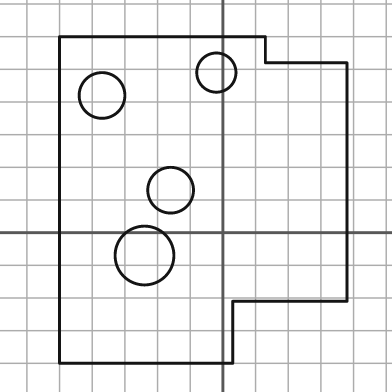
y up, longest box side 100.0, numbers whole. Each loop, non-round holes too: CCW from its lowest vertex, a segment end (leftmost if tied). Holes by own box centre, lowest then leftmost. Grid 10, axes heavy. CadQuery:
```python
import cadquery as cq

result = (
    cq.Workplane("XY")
    .moveTo(-50.0, -40.0)
    .lineTo(3.0, -40.0)
    .lineTo(3.0, -21.0)
    .lineTo(38.0, -21.0)
    .lineTo(38.0, 52.0)
    .lineTo(13.0, 52.0)
    .lineTo(13.0, 60.0)
    .lineTo(-50.0, 60.0)
    .close()
    .moveTo(-24.0, -7.0)
    .circle(9.0)
    .moveTo(-16.0, 13.0)
    .circle(7.0)
    .moveTo(-37.0, 42.0)
    .circle(7.0)
    .moveTo(-2.0, 49.0)
    .circle(6.0)
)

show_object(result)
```